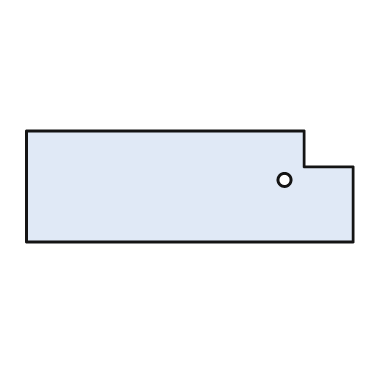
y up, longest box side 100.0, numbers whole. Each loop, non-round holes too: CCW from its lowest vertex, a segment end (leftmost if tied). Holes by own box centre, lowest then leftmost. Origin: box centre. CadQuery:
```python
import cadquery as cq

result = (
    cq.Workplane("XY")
    .moveTo(-50.0, -17.0)
    .lineTo(50.0, -17.0)
    .lineTo(50.0, 6.0)
    .lineTo(35.0, 6.0)
    .lineTo(35.0, 17.0)
    .lineTo(-50.0, 17.0)
    .close()
    .moveTo(29.0, 2.0)
    .circle(2.0)
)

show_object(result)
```